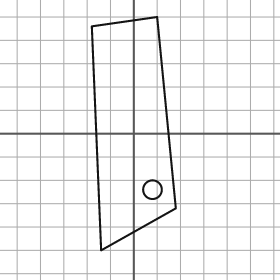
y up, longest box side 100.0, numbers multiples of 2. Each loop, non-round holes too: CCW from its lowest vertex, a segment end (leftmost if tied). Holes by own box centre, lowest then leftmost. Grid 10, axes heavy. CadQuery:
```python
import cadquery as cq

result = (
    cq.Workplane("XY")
    .moveTo(-14.0, -50.0)
    .lineTo(18.0, -32.0)
    .lineTo(10.0, 50.0)
    .lineTo(-18.0, 46.0)
    .close()
    .moveTo(8.0, -24.0)
    .circle(4.0)
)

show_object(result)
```